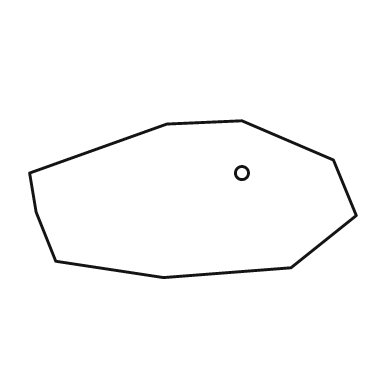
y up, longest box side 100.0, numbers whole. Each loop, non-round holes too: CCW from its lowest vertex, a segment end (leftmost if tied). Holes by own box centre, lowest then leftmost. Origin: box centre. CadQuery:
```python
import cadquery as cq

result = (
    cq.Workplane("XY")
    .moveTo(-9.0, -24.0)
    .lineTo(30.0, -21.0)
    .lineTo(50.0, -5.0)
    .lineTo(43.0, 12.0)
    .lineTo(15.0, 24.0)
    .lineTo(-8.0, 23.0)
    .lineTo(-50.0, 8.0)
    .lineTo(-48.0, -4.0)
    .lineTo(-42.0, -19.0)
    .close()
    .moveTo(15.0, 8.0)
    .circle(2.0)
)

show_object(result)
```